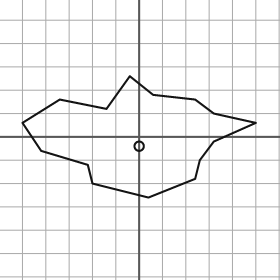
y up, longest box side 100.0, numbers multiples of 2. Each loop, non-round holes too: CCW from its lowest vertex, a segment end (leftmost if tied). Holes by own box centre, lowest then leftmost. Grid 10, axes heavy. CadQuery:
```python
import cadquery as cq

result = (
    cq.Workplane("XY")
    .moveTo(4.0, -26.0)
    .lineTo(24.0, -18.0)
    .lineTo(26.0, -10.0)
    .lineTo(32.0, -2.0)
    .lineTo(50.0, 6.0)
    .lineTo(32.0, 10.0)
    .lineTo(24.0, 16.0)
    .lineTo(6.0, 18.0)
    .lineTo(-4.0, 26.0)
    .lineTo(-14.0, 12.0)
    .lineTo(-34.0, 16.0)
    .lineTo(-50.0, 6.0)
    .lineTo(-42.0, -6.0)
    .lineTo(-22.0, -12.0)
    .lineTo(-20.0, -20.0)
    .close()
    .moveTo(0.0, -4.0)
    .circle(2.0)
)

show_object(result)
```